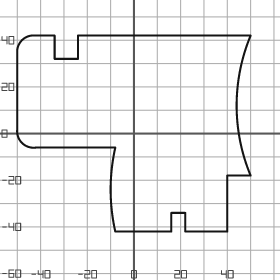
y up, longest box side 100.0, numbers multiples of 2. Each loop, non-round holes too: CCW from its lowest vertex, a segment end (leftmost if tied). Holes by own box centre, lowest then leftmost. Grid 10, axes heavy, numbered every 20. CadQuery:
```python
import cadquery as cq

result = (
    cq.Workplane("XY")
    .moveTo(-8.0, -42.0)
    .lineTo(16.0, -42.0)
    .lineTo(16.0, -34.0)
    .lineTo(22.0, -34.0)
    .lineTo(22.0, -42.0)
    .lineTo(40.0, -42.0)
    .lineTo(40.0, -18.0)
    .lineTo(50.0, -18.0)
    .threePointArc((44.0, 12.0), (50.0, 42.0))
    .lineTo(-24.0, 42.0)
    .lineTo(-24.0, 32.0)
    .lineTo(-34.0, 32.0)
    .lineTo(-34.0, 42.0)
    .lineTo(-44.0, 42.0)
    .threePointArc((-48.0, 40.0), (-50.0, 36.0))
    .lineTo(-50.0, 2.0)
    .threePointArc((-48.0, -4.0), (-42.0, -6.0))
    .lineTo(-8.0, -6.0)
    .threePointArc((-10.0, -24.0), (-8.0, -42.0))
    .close()
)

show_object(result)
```